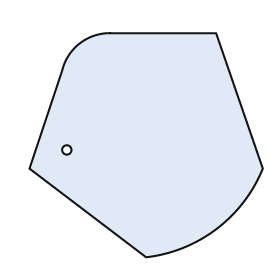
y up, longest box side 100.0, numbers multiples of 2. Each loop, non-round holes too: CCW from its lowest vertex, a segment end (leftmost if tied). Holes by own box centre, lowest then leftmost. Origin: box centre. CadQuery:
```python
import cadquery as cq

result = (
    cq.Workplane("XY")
    .moveTo(0.0, -48.0)
    .threePointArc((30.0, -36.0), (50.0, -10.0))
    .lineTo(30.0, 48.0)
    .lineTo(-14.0, 48.0)
    .threePointArc((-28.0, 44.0), (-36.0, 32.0))
    .lineTo(-50.0, -10.0)
    .close()
    .moveTo(-34.0, -2.0)
    .circle(2.0)
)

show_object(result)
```